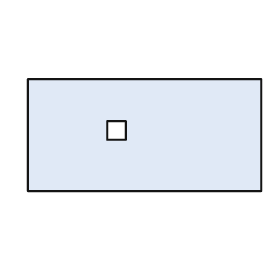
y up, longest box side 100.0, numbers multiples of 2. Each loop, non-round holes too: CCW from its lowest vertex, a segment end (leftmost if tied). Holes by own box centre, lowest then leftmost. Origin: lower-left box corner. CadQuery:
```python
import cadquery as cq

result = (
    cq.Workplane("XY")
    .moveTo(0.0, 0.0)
    .lineTo(100.0, 0.0)
    .lineTo(100.0, 48.0)
    .lineTo(0.0, 48.0)
    .close()
    .moveTo(34.0, 22.0)
    .lineTo(42.0, 22.0)
    .lineTo(42.0, 30.0)
    .lineTo(34.0, 30.0)
    .close()
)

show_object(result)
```